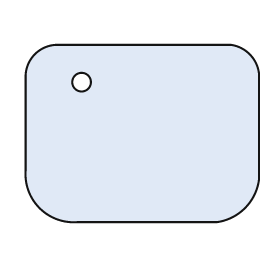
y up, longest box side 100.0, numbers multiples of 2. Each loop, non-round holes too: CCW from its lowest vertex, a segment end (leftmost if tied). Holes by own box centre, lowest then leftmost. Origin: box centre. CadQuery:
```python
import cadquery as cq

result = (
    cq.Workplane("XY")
    .moveTo(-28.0, -38.0)
    .lineTo(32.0, -38.0)
    .threePointArc((44.0, -32.0), (50.0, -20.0))
    .lineTo(50.0, 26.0)
    .threePointArc((46.0, 34.0), (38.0, 38.0))
    .lineTo(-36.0, 38.0)
    .threePointArc((-46.0, 34.0), (-50.0, 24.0))
    .lineTo(-50.0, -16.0)
    .threePointArc((-44.0, -32.0), (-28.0, -38.0))
    .close()
    .moveTo(-26.0, 22.0)
    .circle(4.0)
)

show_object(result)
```